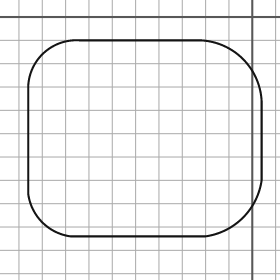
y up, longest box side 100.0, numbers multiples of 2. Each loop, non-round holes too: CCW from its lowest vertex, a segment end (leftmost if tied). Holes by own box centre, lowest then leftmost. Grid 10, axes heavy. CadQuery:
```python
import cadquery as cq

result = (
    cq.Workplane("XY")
    .moveTo(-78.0, -94.0)
    .lineTo(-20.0, -94.0)
    .threePointArc((-4.0, -86.0), (4.0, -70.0))
    .lineTo(4.0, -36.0)
    .threePointArc((-4.0, -18.0), (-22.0, -10.0))
    .lineTo(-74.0, -10.0)
    .threePointArc((-90.0, -16.0), (-96.0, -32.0))
    .lineTo(-96.0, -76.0)
    .threePointArc((-90.0, -88.0), (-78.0, -94.0))
    .close()
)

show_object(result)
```